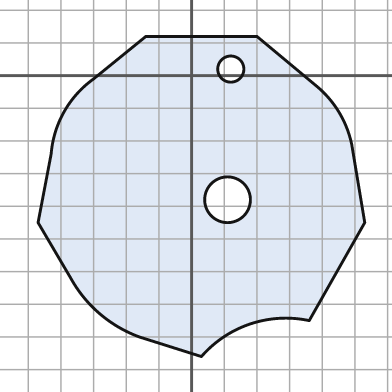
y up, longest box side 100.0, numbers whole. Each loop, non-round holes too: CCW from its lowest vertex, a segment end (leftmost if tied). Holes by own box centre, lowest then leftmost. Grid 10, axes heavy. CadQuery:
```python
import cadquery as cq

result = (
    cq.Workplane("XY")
    .moveTo(3.0, -86.0)
    .threePointArc((18.0, -76.0), (36.0, -75.0))
    .lineTo(53.0, -45.0)
    .lineTo(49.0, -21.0)
    .threePointArc((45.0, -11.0), (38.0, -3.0))
    .lineTo(20.0, 12.0)
    .lineTo(-14.0, 12.0)
    .lineTo(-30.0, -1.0)
    .threePointArc((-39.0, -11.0), (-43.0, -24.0))
    .lineTo(-47.0, -45.0)
    .lineTo(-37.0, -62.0)
    .threePointArc((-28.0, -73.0), (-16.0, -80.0))
    .close()
    .moveTo(11.0, -38.0)
    .circle(7.0)
    .moveTo(12.0, 2.0)
    .circle(4.0)
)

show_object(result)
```